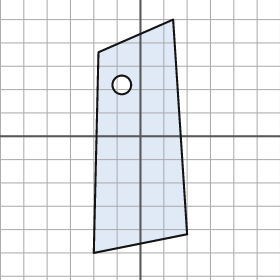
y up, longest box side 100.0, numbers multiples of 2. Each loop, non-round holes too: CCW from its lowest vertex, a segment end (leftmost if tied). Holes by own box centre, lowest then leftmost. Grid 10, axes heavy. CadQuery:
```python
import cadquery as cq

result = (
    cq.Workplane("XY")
    .moveTo(-20.0, -50.0)
    .lineTo(20.0, -42.0)
    .lineTo(14.0, 50.0)
    .lineTo(-18.0, 36.0)
    .close()
    .moveTo(-8.0, 22.0)
    .circle(4.0)
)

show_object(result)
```